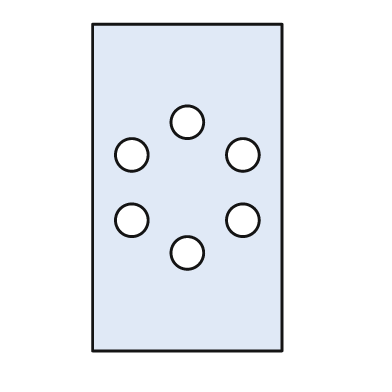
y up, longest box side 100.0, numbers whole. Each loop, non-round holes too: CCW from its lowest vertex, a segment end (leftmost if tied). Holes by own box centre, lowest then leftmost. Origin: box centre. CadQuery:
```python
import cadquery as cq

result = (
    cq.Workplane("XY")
    .moveTo(-29.0, -50.0)
    .lineTo(29.0, -50.0)
    .lineTo(29.0, 50.0)
    .lineTo(-29.0, 50.0)
    .close()
    .moveTo(0.0, -20.0)
    .circle(5.0)
    .moveTo(-17.0, -10.0)
    .circle(5.0)
    .moveTo(17.0, -10.0)
    .circle(5.0)
    .moveTo(-17.0, 10.0)
    .circle(5.0)
    .moveTo(17.0, 10.0)
    .circle(5.0)
    .moveTo(0.0, 20.0)
    .circle(5.0)
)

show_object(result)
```